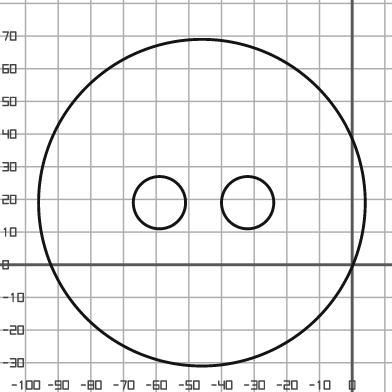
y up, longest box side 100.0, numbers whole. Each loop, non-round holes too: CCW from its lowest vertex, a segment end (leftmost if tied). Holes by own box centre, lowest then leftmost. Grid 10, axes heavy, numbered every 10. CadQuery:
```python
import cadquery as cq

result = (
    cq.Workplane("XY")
    .moveTo(-46.0, 19.0)
    .circle(50.0)
    .moveTo(-59.0, 19.0)
    .circle(8.0)
    .moveTo(-32.0, 19.0)
    .circle(8.0)
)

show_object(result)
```